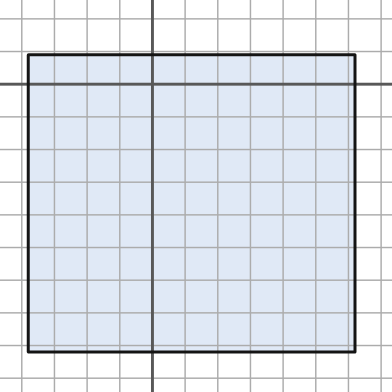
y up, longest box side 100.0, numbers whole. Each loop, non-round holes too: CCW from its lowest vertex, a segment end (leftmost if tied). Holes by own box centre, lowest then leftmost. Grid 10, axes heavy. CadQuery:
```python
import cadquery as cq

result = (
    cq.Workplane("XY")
    .moveTo(-38.0, -82.0)
    .lineTo(62.0, -82.0)
    .lineTo(62.0, 9.0)
    .lineTo(-38.0, 9.0)
    .close()
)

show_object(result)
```